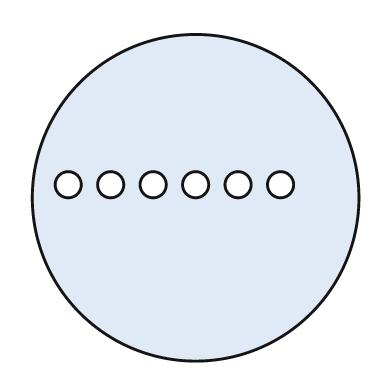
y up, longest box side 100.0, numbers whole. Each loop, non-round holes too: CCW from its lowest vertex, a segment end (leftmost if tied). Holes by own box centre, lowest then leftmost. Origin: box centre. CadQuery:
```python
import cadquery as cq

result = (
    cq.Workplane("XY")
    .moveTo(0.0, 0.0)
    .circle(50.0)
    .moveTo(-39.0, 4.0)
    .circle(4.0)
    .moveTo(-26.0, 4.0)
    .circle(4.0)
    .moveTo(-13.0, 4.0)
    .circle(4.0)
    .moveTo(0.0, 4.0)
    .circle(4.0)
    .moveTo(13.0, 4.0)
    .circle(4.0)
    .moveTo(26.0, 4.0)
    .circle(4.0)
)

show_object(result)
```